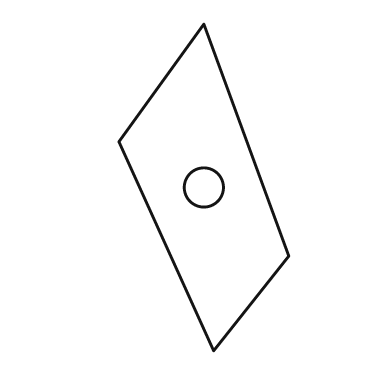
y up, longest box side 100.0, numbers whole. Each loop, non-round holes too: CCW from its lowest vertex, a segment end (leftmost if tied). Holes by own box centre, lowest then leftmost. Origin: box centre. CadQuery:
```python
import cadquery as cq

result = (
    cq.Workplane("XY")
    .moveTo(3.0, -50.0)
    .lineTo(26.0, -21.0)
    .lineTo(0.0, 50.0)
    .lineTo(-26.0, 14.0)
    .close()
    .moveTo(0.0, 0.0)
    .circle(6.0)
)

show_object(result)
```